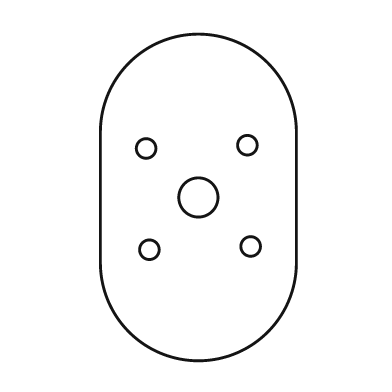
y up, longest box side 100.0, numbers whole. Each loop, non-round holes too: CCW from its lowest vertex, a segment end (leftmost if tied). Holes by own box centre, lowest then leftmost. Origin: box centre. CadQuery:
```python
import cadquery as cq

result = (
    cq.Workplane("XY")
    .moveTo(-30.0, -20.0)
    .threePointArc((0.0, -50.0), (30.0, -20.0))
    .lineTo(30.0, 20.0)
    .threePointArc((0.0, 50.0), (-30.0, 20.0))
    .close()
    .moveTo(-15.0, -16.0)
    .circle(3.0)
    .moveTo(16.0, -15.0)
    .circle(3.0)
    .moveTo(0.0, 0.0)
    .circle(6.0)
    .moveTo(-16.0, 15.0)
    .circle(3.0)
    .moveTo(15.0, 16.0)
    .circle(3.0)
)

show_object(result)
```